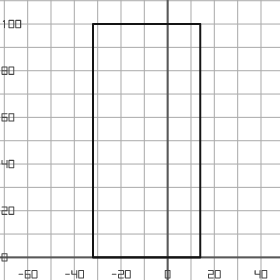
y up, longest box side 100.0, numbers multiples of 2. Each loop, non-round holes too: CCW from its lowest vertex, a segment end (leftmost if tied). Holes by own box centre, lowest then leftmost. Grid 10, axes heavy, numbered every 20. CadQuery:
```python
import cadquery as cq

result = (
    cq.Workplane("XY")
    .moveTo(-32.0, 0.0)
    .lineTo(14.0, 0.0)
    .lineTo(14.0, 100.0)
    .lineTo(-32.0, 100.0)
    .close()
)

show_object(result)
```